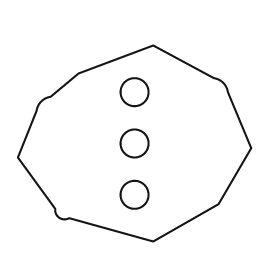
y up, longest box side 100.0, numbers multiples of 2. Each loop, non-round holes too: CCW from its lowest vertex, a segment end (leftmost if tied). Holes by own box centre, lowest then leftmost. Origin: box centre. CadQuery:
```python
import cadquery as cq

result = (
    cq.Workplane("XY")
    .moveTo(8.0, -42.0)
    .lineTo(36.0, -26.0)
    .lineTo(50.0, -2.0)
    .lineTo(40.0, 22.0)
    .threePointArc((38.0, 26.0), (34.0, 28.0))
    .lineTo(8.0, 42.0)
    .lineTo(-24.0, 30.0)
    .lineTo(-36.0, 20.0)
    .threePointArc((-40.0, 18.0), (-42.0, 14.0))
    .lineTo(-50.0, -6.0)
    .lineTo(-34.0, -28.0)
    .threePointArc((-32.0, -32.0), (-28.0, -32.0))
    .close()
    .moveTo(0.0, -22.0)
    .circle(6.0)
    .moveTo(0.0, 0.0)
    .circle(6.0)
    .moveTo(0.0, 22.0)
    .circle(6.0)
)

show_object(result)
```